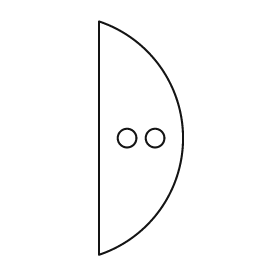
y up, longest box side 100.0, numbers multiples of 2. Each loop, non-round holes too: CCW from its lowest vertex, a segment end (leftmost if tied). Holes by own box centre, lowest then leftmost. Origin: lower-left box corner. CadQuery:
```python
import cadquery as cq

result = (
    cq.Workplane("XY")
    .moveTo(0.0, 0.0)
    .threePointArc((36.0, 50.0), (0.0, 100.0))
    .close()
    .moveTo(12.0, 50.0)
    .circle(4.0)
    .moveTo(24.0, 50.0)
    .circle(4.0)
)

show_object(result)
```